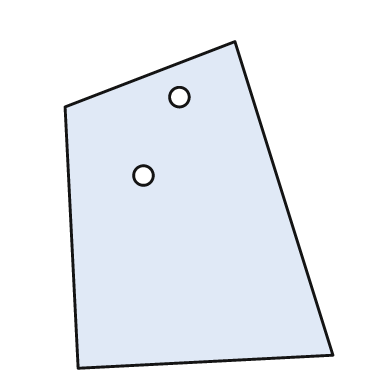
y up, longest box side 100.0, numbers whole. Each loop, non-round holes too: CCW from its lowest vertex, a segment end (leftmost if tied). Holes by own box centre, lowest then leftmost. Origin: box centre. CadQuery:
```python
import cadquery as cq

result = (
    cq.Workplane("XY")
    .moveTo(-37.0, -50.0)
    .lineTo(41.0, -46.0)
    .lineTo(11.0, 50.0)
    .lineTo(-41.0, 30.0)
    .close()
    .moveTo(-17.0, 9.0)
    .circle(3.0)
    .moveTo(-6.0, 33.0)
    .circle(3.0)
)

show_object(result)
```